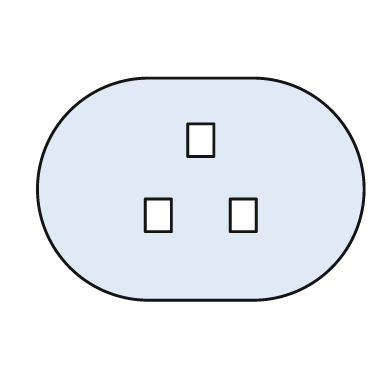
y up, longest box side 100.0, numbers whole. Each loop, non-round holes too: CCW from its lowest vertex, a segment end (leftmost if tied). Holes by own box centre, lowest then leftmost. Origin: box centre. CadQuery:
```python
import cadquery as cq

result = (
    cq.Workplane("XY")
    .moveTo(-16.0, -34.0)
    .lineTo(16.0, -34.0)
    .threePointArc((50.0, 0.0), (16.0, 34.0))
    .lineTo(-16.0, 34.0)
    .threePointArc((-50.0, 0.0), (-16.0, -34.0))
    .close()
    .moveTo(-17.0, -13.0)
    .lineTo(-9.0, -13.0)
    .lineTo(-9.0, -3.0)
    .lineTo(-17.0, -3.0)
    .close()
    .moveTo(9.0, -13.0)
    .lineTo(17.0, -13.0)
    .lineTo(17.0, -3.0)
    .lineTo(9.0, -3.0)
    .close()
    .moveTo(-4.0, 10.0)
    .lineTo(4.0, 10.0)
    .lineTo(4.0, 20.0)
    .lineTo(-4.0, 20.0)
    .close()
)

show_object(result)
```